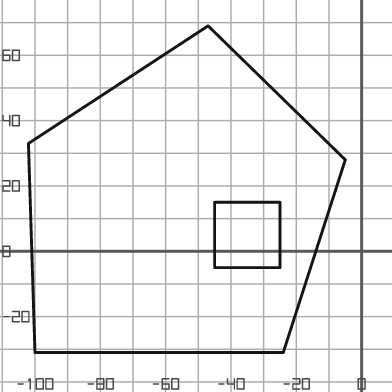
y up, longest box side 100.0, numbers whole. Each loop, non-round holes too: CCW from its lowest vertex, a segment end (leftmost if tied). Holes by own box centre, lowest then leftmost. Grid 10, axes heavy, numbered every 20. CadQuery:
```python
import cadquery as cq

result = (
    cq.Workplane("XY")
    .moveTo(-100.0, -31.0)
    .lineTo(-24.0, -31.0)
    .lineTo(-5.0, 28.0)
    .lineTo(-47.0, 69.0)
    .lineTo(-102.0, 33.0)
    .close()
    .moveTo(-45.0, -5.0)
    .lineTo(-25.0, -5.0)
    .lineTo(-25.0, 15.0)
    .lineTo(-45.0, 15.0)
    .close()
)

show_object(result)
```